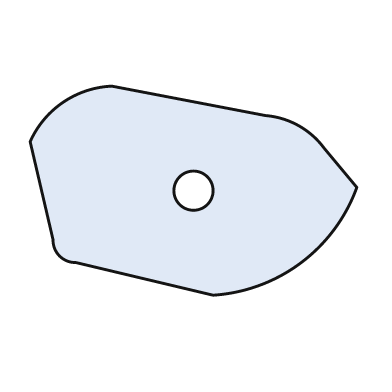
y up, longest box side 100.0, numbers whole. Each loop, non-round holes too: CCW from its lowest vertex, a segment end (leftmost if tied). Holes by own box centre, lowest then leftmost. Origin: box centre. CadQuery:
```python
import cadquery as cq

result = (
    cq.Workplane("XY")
    .moveTo(6.0, -32.0)
    .threePointArc((33.0, -22.0), (50.0, 1.0))
    .lineTo(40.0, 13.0)
    .threePointArc((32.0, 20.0), (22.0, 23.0))
    .lineTo(-25.0, 32.0)
    .threePointArc((-40.0, 27.0), (-50.0, 15.0))
    .lineTo(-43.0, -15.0)
    .threePointArc((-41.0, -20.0), (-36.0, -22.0))
    .close()
    .moveTo(0.0, 0.0)
    .circle(6.0)
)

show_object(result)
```